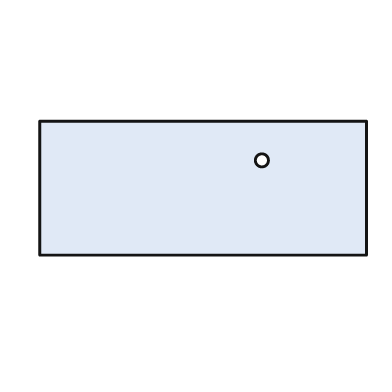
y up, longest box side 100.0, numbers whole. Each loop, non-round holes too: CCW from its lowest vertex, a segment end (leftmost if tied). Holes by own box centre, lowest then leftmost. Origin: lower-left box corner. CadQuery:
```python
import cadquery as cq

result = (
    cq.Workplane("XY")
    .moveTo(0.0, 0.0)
    .lineTo(100.0, 0.0)
    .lineTo(100.0, 41.0)
    .lineTo(0.0, 41.0)
    .close()
    .moveTo(68.0, 29.0)
    .circle(2.0)
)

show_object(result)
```